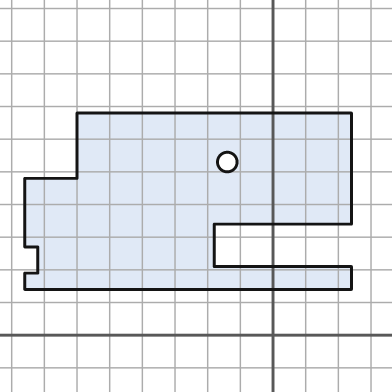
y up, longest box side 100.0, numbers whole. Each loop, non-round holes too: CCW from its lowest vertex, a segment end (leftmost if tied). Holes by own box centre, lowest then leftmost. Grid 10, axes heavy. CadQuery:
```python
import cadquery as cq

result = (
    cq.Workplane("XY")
    .moveTo(-76.0, 14.0)
    .lineTo(24.0, 14.0)
    .lineTo(24.0, 21.0)
    .lineTo(-18.0, 21.0)
    .lineTo(-18.0, 34.0)
    .lineTo(24.0, 34.0)
    .lineTo(24.0, 68.0)
    .lineTo(-60.0, 68.0)
    .lineTo(-60.0, 48.0)
    .lineTo(-76.0, 48.0)
    .lineTo(-76.0, 27.0)
    .lineTo(-72.0, 27.0)
    .lineTo(-72.0, 19.0)
    .lineTo(-76.0, 19.0)
    .close()
    .moveTo(-14.0, 53.0)
    .circle(3.0)
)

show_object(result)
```